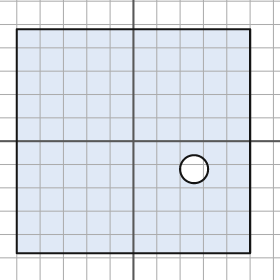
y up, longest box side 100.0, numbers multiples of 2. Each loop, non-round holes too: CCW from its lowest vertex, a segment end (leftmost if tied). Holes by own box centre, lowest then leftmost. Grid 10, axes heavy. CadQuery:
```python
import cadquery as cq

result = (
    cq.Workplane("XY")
    .moveTo(-50.0, -48.0)
    .lineTo(50.0, -48.0)
    .lineTo(50.0, 48.0)
    .lineTo(-50.0, 48.0)
    .close()
    .moveTo(26.0, -12.0)
    .circle(6.0)
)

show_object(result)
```